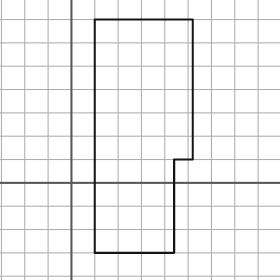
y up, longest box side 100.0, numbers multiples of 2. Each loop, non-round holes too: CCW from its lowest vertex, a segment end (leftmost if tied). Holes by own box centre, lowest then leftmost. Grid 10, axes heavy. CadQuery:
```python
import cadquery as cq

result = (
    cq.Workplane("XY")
    .moveTo(10.0, -30.0)
    .lineTo(44.0, -30.0)
    .lineTo(44.0, 10.0)
    .lineTo(52.0, 10.0)
    .lineTo(52.0, 70.0)
    .lineTo(10.0, 70.0)
    .close()
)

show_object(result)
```